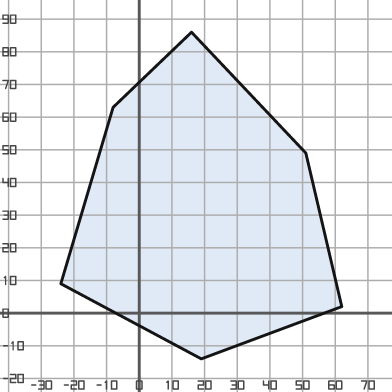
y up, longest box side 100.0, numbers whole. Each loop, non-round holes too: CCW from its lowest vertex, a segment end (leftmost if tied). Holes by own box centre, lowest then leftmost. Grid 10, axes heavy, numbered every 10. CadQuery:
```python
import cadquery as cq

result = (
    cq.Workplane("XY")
    .moveTo(19.0, -14.0)
    .lineTo(62.0, 2.0)
    .lineTo(51.0, 49.0)
    .lineTo(16.0, 86.0)
    .lineTo(-8.0, 63.0)
    .lineTo(-24.0, 9.0)
    .close()
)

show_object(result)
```